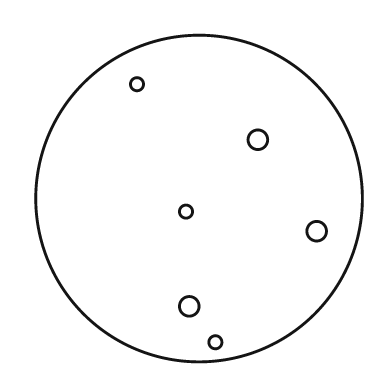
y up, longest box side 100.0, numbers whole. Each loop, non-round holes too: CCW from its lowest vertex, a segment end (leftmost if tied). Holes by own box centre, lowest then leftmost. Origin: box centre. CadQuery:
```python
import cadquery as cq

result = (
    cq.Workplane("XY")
    .moveTo(0.0, 0.0)
    .circle(50.0)
    .moveTo(5.0, -44.0)
    .circle(2.0)
    .moveTo(-3.0, -33.0)
    .circle(3.0)
    .moveTo(36.0, -10.0)
    .circle(3.0)
    .moveTo(-4.0, -4.0)
    .circle(2.0)
    .moveTo(18.0, 18.0)
    .circle(3.0)
    .moveTo(-19.0, 35.0)
    .circle(2.0)
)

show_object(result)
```